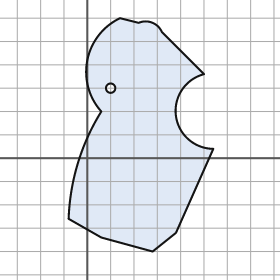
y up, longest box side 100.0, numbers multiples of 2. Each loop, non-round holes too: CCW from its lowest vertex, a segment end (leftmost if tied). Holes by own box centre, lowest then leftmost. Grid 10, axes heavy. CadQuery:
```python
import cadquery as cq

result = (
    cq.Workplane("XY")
    .moveTo(28.0, -40.0)
    .lineTo(38.0, -32.0)
    .lineTo(54.0, 4.0)
    .threePointArc((38.0, 18.0), (50.0, 36.0))
    .lineTo(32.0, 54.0)
    .threePointArc((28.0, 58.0), (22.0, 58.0))
    .lineTo(14.0, 60.0)
    .threePointArc((0.0, 42.0), (6.0, 20.0))
    .threePointArc((-4.0, -2.0), (-8.0, -26.0))
    .lineTo(6.0, -34.0)
    .close()
    .moveTo(10.0, 30.0)
    .circle(2.0)
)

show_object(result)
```